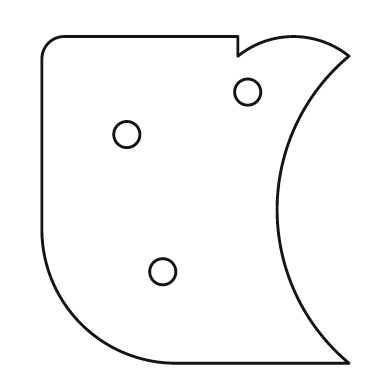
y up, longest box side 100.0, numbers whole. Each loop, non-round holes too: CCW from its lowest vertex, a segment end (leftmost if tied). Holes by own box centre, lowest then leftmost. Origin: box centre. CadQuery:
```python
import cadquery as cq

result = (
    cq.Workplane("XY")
    .moveTo(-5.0, -50.0)
    .lineTo(47.0, -50.0)
    .threePointArc((25.0, -3.0), (47.0, 44.0))
    .threePointArc((30.0, 50.0), (13.0, 44.0))
    .lineTo(13.0, 50.0)
    .lineTo(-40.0, 50.0)
    .threePointArc((-45.0, 48.0), (-47.0, 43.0))
    .lineTo(-47.0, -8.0)
    .threePointArc((-35.0, -38.0), (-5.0, -50.0))
    .close()
    .moveTo(-10.0, -22.0)
    .circle(4.0)
    .moveTo(-21.0, 20.0)
    .circle(4.0)
    .moveTo(16.0, 33.0)
    .circle(4.0)
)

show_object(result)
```